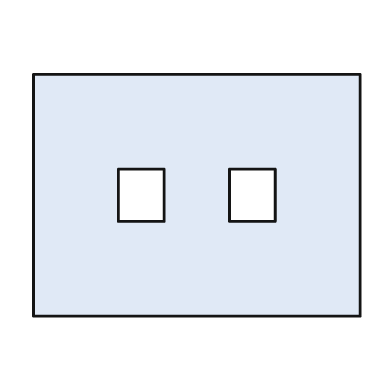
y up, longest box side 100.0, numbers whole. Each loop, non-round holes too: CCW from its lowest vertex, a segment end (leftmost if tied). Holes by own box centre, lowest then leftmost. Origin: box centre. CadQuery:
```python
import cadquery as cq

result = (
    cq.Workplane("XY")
    .moveTo(-50.0, -37.0)
    .lineTo(50.0, -37.0)
    .lineTo(50.0, 37.0)
    .lineTo(-50.0, 37.0)
    .close()
    .moveTo(-24.0, -8.0)
    .lineTo(-10.0, -8.0)
    .lineTo(-10.0, 8.0)
    .lineTo(-24.0, 8.0)
    .close()
    .moveTo(10.0, -8.0)
    .lineTo(24.0, -8.0)
    .lineTo(24.0, 8.0)
    .lineTo(10.0, 8.0)
    .close()
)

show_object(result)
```